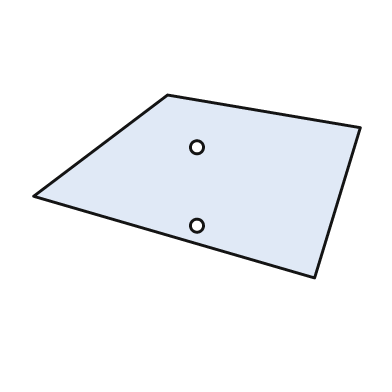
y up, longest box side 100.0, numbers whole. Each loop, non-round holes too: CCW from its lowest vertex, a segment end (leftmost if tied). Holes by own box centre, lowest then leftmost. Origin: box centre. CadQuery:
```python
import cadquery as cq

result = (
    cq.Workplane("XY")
    .moveTo(36.0, -28.0)
    .lineTo(50.0, 18.0)
    .lineTo(-9.0, 28.0)
    .lineTo(-50.0, -3.0)
    .close()
    .moveTo(0.0, -12.0)
    .circle(2.0)
    .moveTo(0.0, 12.0)
    .circle(2.0)
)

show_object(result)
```